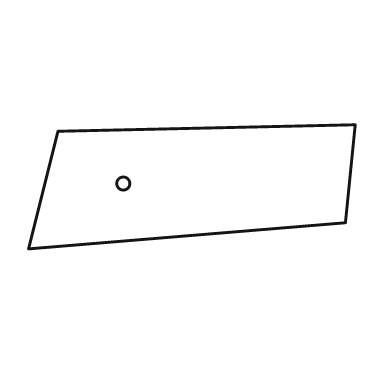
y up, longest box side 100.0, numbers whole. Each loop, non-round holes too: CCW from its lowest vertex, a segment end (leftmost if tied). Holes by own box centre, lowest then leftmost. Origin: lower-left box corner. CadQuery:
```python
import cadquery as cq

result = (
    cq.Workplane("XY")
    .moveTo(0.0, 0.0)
    .lineTo(97.0, 8.0)
    .lineTo(100.0, 38.0)
    .lineTo(9.0, 36.0)
    .close()
    .moveTo(29.0, 20.0)
    .circle(2.0)
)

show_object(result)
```